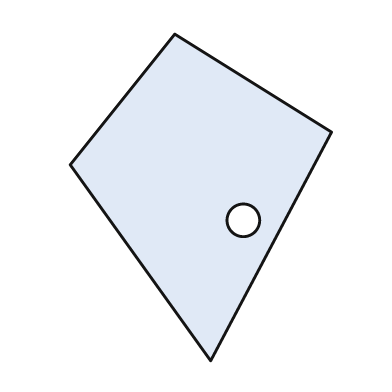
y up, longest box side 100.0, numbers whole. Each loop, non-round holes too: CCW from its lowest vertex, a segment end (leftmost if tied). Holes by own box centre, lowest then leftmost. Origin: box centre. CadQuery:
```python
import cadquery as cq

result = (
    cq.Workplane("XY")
    .moveTo(3.0, -50.0)
    .lineTo(40.0, 20.0)
    .lineTo(-8.0, 50.0)
    .lineTo(-40.0, 10.0)
    .close()
    .moveTo(13.0, -7.0)
    .circle(5.0)
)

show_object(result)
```